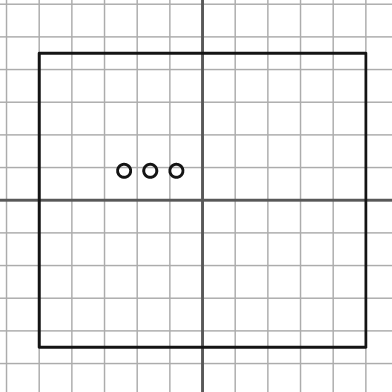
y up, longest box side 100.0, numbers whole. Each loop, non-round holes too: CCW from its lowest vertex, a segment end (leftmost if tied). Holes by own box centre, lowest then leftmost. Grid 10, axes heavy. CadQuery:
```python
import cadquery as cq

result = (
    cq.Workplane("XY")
    .moveTo(-50.0, -45.0)
    .lineTo(50.0, -45.0)
    .lineTo(50.0, 45.0)
    .lineTo(-50.0, 45.0)
    .close()
    .moveTo(-24.0, 9.0)
    .circle(2.0)
    .moveTo(-16.0, 9.0)
    .circle(2.0)
    .moveTo(-8.0, 9.0)
    .circle(2.0)
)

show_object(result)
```